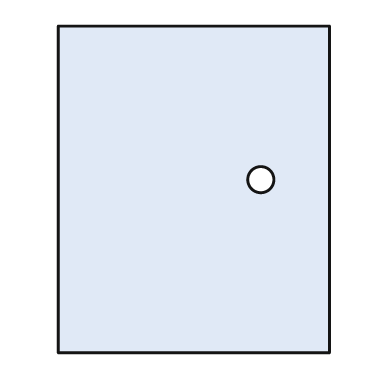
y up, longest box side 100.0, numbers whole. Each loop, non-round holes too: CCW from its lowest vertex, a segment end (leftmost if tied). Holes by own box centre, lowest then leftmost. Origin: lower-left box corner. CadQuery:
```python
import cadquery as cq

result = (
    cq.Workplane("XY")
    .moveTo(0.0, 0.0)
    .lineTo(83.0, 0.0)
    .lineTo(83.0, 100.0)
    .lineTo(0.0, 100.0)
    .close()
    .moveTo(62.0, 53.0)
    .circle(4.0)
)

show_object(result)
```